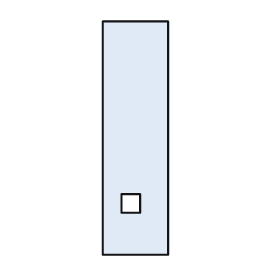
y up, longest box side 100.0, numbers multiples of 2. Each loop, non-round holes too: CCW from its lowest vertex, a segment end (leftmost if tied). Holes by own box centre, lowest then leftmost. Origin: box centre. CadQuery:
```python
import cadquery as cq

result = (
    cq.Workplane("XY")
    .moveTo(-14.0, -50.0)
    .lineTo(14.0, -50.0)
    .lineTo(14.0, 50.0)
    .lineTo(-14.0, 50.0)
    .close()
    .moveTo(-6.0, -32.0)
    .lineTo(2.0, -32.0)
    .lineTo(2.0, -24.0)
    .lineTo(-6.0, -24.0)
    .close()
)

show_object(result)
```